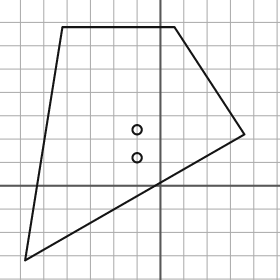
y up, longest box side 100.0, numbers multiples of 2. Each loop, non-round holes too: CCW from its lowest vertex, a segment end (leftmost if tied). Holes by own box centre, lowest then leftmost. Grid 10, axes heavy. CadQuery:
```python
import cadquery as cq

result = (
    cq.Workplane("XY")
    .moveTo(-58.0, -32.0)
    .lineTo(36.0, 22.0)
    .lineTo(6.0, 68.0)
    .lineTo(-42.0, 68.0)
    .close()
    .moveTo(-10.0, 12.0)
    .circle(2.0)
    .moveTo(-10.0, 24.0)
    .circle(2.0)
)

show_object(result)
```